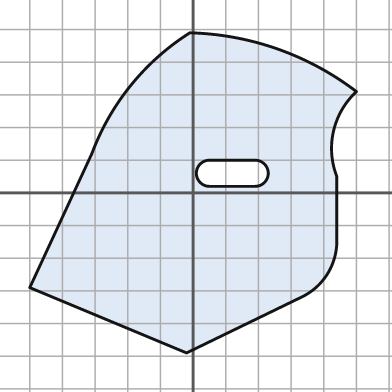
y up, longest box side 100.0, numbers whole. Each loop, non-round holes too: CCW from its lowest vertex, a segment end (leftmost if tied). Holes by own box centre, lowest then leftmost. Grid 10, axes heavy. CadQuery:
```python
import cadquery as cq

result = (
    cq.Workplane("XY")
    .moveTo(-2.0, -49.0)
    .lineTo(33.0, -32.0)
    .threePointArc((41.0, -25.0), (44.0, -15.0))
    .lineTo(44.0, 5.0)
    .threePointArc((43.0, 19.0), (50.0, 31.0))
    .threePointArc((26.0, 44.0), (-1.0, 49.0))
    .threePointArc((-19.0, 33.0), (-31.0, 12.0))
    .lineTo(-50.0, -29.0)
    .close()
    .moveTo(5.0, 2.0)
    .lineTo(19.0, 2.0)
    .threePointArc((23.0, 6.0), (19.0, 10.0))
    .lineTo(5.0, 10.0)
    .threePointArc((1.0, 6.0), (5.0, 2.0))
    .close()
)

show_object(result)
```